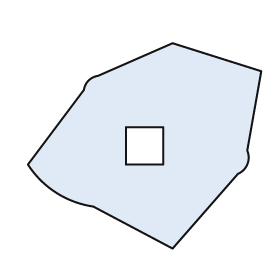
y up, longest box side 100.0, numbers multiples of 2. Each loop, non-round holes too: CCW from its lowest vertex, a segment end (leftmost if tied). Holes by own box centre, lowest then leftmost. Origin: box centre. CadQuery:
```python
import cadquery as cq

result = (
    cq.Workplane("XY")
    .moveTo(12.0, -44.0)
    .lineTo(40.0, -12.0)
    .threePointArc((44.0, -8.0), (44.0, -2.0))
    .lineTo(50.0, 32.0)
    .lineTo(12.0, 44.0)
    .lineTo(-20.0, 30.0)
    .threePointArc((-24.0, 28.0), (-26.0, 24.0))
    .lineTo(-50.0, -8.0)
    .threePointArc((-38.0, -20.0), (-22.0, -26.0))
    .close()
    .moveTo(-8.0, -8.0)
    .lineTo(8.0, -8.0)
    .lineTo(8.0, 8.0)
    .lineTo(-8.0, 8.0)
    .close()
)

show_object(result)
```